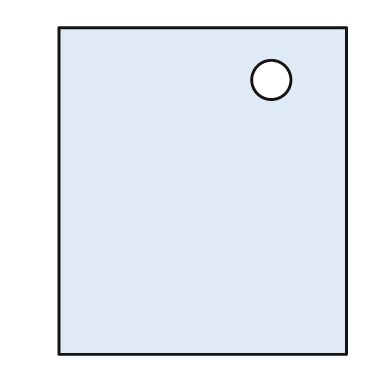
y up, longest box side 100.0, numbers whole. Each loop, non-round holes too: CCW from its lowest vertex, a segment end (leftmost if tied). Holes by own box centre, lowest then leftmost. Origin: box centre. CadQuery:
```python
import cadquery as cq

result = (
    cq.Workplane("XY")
    .moveTo(-44.0, -50.0)
    .lineTo(44.0, -50.0)
    .lineTo(44.0, 50.0)
    .lineTo(-44.0, 50.0)
    .close()
    .moveTo(21.0, 34.0)
    .circle(6.0)
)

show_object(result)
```